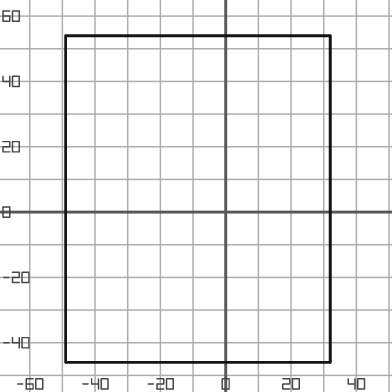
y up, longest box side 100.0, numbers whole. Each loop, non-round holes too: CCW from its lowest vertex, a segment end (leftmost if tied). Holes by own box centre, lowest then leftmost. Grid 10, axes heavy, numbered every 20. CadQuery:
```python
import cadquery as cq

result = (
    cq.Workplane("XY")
    .moveTo(-49.0, -46.0)
    .lineTo(32.0, -46.0)
    .lineTo(32.0, 54.0)
    .lineTo(-49.0, 54.0)
    .close()
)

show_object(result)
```